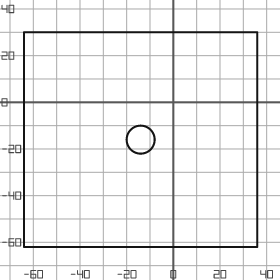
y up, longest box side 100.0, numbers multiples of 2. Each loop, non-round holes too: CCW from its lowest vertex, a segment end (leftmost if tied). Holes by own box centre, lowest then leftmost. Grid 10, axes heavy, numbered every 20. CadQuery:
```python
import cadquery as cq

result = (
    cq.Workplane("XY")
    .moveTo(-64.0, -62.0)
    .lineTo(36.0, -62.0)
    .lineTo(36.0, 30.0)
    .lineTo(-64.0, 30.0)
    .close()
    .moveTo(-14.0, -16.0)
    .circle(6.0)
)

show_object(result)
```